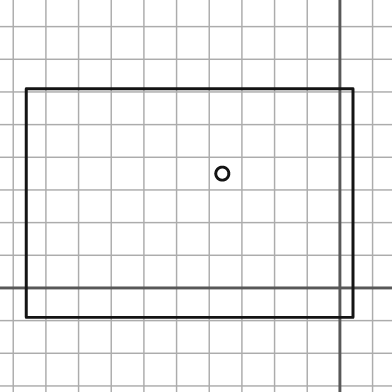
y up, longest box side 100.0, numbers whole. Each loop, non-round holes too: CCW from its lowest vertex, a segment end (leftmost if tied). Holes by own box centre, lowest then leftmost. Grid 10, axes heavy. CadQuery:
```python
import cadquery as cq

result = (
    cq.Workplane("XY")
    .moveTo(-96.0, -9.0)
    .lineTo(4.0, -9.0)
    .lineTo(4.0, 61.0)
    .lineTo(-96.0, 61.0)
    .close()
    .moveTo(-36.0, 35.0)
    .circle(2.0)
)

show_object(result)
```